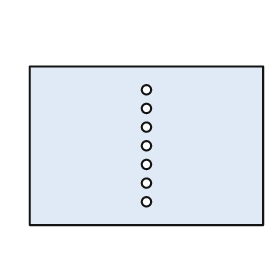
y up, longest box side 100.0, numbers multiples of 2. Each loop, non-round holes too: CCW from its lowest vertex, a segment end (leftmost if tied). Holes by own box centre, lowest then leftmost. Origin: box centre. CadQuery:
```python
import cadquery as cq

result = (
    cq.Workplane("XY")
    .moveTo(-50.0, -34.0)
    .lineTo(50.0, -34.0)
    .lineTo(50.0, 34.0)
    .lineTo(-50.0, 34.0)
    .close()
    .moveTo(0.0, -24.0)
    .circle(2.0)
    .moveTo(0.0, -16.0)
    .circle(2.0)
    .moveTo(0.0, -8.0)
    .circle(2.0)
    .moveTo(0.0, 0.0)
    .circle(2.0)
    .moveTo(0.0, 8.0)
    .circle(2.0)
    .moveTo(0.0, 16.0)
    .circle(2.0)
    .moveTo(0.0, 24.0)
    .circle(2.0)
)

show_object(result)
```